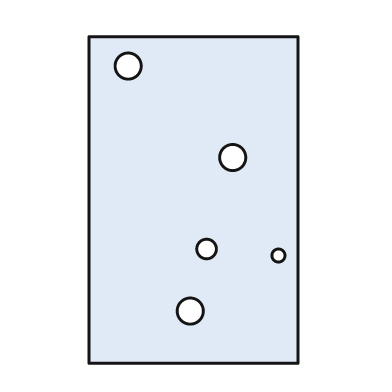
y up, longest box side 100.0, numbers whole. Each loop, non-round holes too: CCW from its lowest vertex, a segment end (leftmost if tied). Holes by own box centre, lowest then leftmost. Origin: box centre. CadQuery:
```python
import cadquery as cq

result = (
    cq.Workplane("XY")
    .moveTo(-32.0, -50.0)
    .lineTo(32.0, -50.0)
    .lineTo(32.0, 50.0)
    .lineTo(-32.0, 50.0)
    .close()
    .moveTo(-1.0, -34.0)
    .circle(4.0)
    .moveTo(26.0, -17.0)
    .circle(2.0)
    .moveTo(4.0, -15.0)
    .circle(3.0)
    .moveTo(12.0, 13.0)
    .circle(4.0)
    .moveTo(-20.0, 41.0)
    .circle(4.0)
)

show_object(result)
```